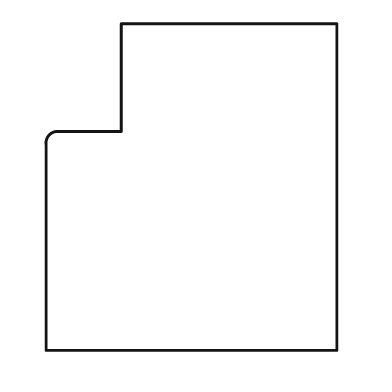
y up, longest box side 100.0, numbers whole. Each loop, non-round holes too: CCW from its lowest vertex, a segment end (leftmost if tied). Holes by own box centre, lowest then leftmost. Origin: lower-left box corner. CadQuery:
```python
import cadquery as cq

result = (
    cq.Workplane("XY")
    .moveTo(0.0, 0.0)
    .lineTo(89.0, 0.0)
    .lineTo(89.0, 100.0)
    .lineTo(23.0, 100.0)
    .lineTo(23.0, 67.0)
    .lineTo(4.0, 67.0)
    .threePointArc((1.0, 66.0), (0.0, 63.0))
    .close()
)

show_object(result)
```